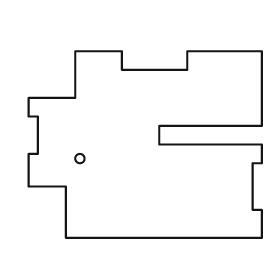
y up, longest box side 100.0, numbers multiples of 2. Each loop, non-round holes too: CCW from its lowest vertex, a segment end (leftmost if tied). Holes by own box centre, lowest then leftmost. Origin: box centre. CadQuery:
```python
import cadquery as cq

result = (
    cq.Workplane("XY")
    .moveTo(-34.0, -40.0)
    .lineTo(50.0, -40.0)
    .lineTo(50.0, -28.0)
    .lineTo(46.0, -28.0)
    .lineTo(46.0, -8.0)
    .lineTo(50.0, -8.0)
    .lineTo(50.0, 0.0)
    .lineTo(6.0, 0.0)
    .lineTo(6.0, 8.0)
    .lineTo(50.0, 8.0)
    .lineTo(50.0, 40.0)
    .lineTo(18.0, 40.0)
    .lineTo(18.0, 32.0)
    .lineTo(-10.0, 32.0)
    .lineTo(-10.0, 40.0)
    .lineTo(-30.0, 40.0)
    .lineTo(-30.0, 20.0)
    .lineTo(-50.0, 20.0)
    .lineTo(-50.0, 12.0)
    .lineTo(-46.0, 12.0)
    .lineTo(-46.0, -4.0)
    .lineTo(-50.0, -4.0)
    .lineTo(-50.0, -18.0)
    .lineTo(-34.0, -18.0)
    .close()
    .moveTo(-28.0, -6.0)
    .circle(2.0)
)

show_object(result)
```